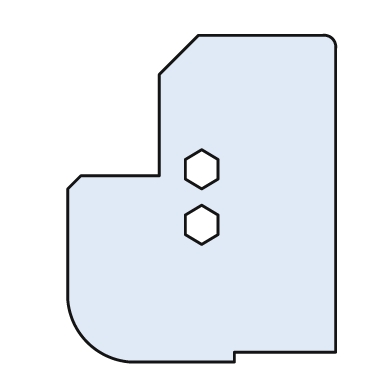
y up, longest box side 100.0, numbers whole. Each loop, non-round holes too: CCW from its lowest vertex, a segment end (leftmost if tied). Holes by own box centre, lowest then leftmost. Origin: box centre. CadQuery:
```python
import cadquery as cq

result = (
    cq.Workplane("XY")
    .moveTo(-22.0, -50.0)
    .lineTo(10.0, -50.0)
    .lineTo(10.0, -47.0)
    .lineTo(41.0, -47.0)
    .lineTo(41.0, 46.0)
    .threePointArc((40.0, 49.0), (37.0, 50.0))
    .lineTo(-1.0, 50.0)
    .lineTo(-13.0, 38.0)
    .lineTo(-13.0, 7.0)
    .lineTo(-37.0, 7.0)
    .lineTo(-41.0, 3.0)
    .lineTo(-41.0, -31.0)
    .threePointArc((-35.0, -44.0), (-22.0, -50.0))
    .close()
    .moveTo(0.0, -14.0)
    .lineTo(5.0, -11.0)
    .lineTo(5.0, -5.0)
    .lineTo(0.0, -2.0)
    .lineTo(-5.0, -5.0)
    .lineTo(-5.0, -11.0)
    .close()
    .moveTo(0.0, 3.0)
    .lineTo(5.0, 6.0)
    .lineTo(5.0, 12.0)
    .lineTo(0.0, 15.0)
    .lineTo(-5.0, 12.0)
    .lineTo(-5.0, 6.0)
    .close()
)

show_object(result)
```